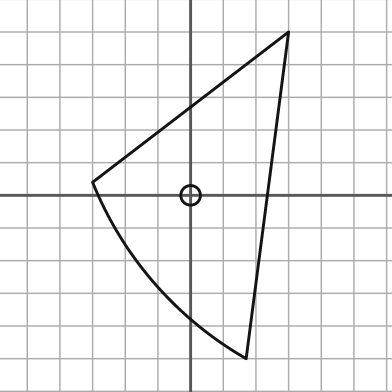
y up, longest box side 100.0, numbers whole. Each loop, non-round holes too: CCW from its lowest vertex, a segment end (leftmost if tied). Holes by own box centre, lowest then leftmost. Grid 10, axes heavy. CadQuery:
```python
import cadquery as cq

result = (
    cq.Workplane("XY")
    .moveTo(17.0, -50.0)
    .lineTo(30.0, 50.0)
    .lineTo(-30.0, 4.0)
    .threePointArc((-11.0, -27.0), (17.0, -50.0))
    .close()
    .moveTo(0.0, 0.0)
    .circle(3.0)
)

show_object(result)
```